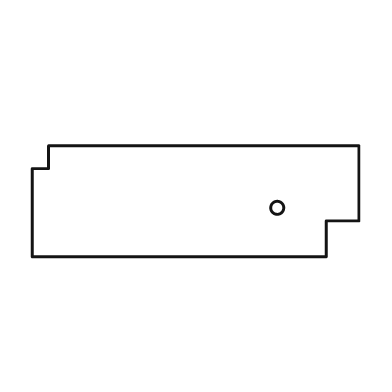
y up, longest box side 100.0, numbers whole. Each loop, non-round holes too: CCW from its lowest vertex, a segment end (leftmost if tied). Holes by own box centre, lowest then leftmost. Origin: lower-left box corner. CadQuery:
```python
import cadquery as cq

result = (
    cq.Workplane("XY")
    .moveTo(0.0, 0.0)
    .lineTo(90.0, 0.0)
    .lineTo(90.0, 11.0)
    .lineTo(100.0, 11.0)
    .lineTo(100.0, 34.0)
    .lineTo(5.0, 34.0)
    .lineTo(5.0, 27.0)
    .lineTo(0.0, 27.0)
    .close()
    .moveTo(75.0, 15.0)
    .circle(2.0)
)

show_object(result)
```